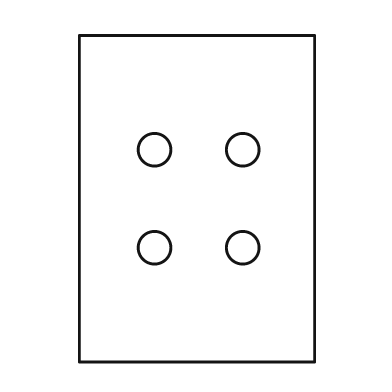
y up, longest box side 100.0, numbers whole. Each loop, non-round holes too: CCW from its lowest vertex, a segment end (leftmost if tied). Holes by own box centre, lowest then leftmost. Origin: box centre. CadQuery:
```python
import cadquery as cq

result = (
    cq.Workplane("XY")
    .moveTo(-36.0, -50.0)
    .lineTo(36.0, -50.0)
    .lineTo(36.0, 50.0)
    .lineTo(-36.0, 50.0)
    .close()
    .moveTo(-13.0, -15.0)
    .circle(5.0)
    .moveTo(14.0, -15.0)
    .circle(5.0)
    .moveTo(-13.0, 15.0)
    .circle(5.0)
    .moveTo(14.0, 15.0)
    .circle(5.0)
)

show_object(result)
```